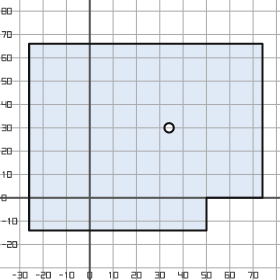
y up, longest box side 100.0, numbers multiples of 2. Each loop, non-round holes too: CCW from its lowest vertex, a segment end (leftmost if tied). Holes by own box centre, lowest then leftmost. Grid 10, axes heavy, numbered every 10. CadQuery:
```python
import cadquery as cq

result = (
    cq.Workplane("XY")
    .moveTo(-26.0, -14.0)
    .lineTo(50.0, -14.0)
    .lineTo(50.0, 0.0)
    .lineTo(74.0, 0.0)
    .lineTo(74.0, 66.0)
    .lineTo(-26.0, 66.0)
    .close()
    .moveTo(34.0, 30.0)
    .circle(2.0)
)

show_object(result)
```